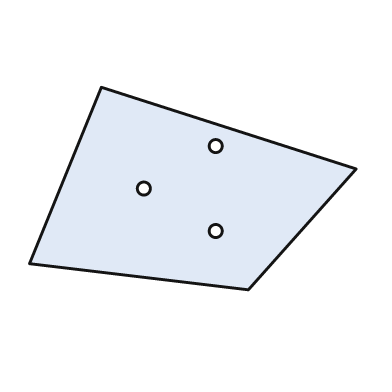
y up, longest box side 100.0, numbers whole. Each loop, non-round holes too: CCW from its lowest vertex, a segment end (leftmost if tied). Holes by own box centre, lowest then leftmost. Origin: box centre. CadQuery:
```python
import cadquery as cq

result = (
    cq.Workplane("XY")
    .moveTo(17.0, -31.0)
    .lineTo(50.0, 6.0)
    .lineTo(-28.0, 31.0)
    .lineTo(-50.0, -23.0)
    .close()
    .moveTo(7.0, -13.0)
    .circle(2.0)
    .moveTo(-15.0, 0.0)
    .circle(2.0)
    .moveTo(7.0, 13.0)
    .circle(2.0)
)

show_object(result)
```